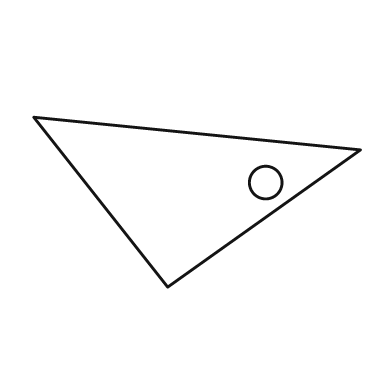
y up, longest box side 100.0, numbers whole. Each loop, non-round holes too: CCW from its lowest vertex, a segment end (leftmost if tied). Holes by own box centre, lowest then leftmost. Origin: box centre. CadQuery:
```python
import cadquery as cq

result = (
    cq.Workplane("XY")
    .moveTo(-9.0, -26.0)
    .lineTo(50.0, 16.0)
    .lineTo(-50.0, 26.0)
    .close()
    .moveTo(21.0, 6.0)
    .circle(5.0)
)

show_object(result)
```